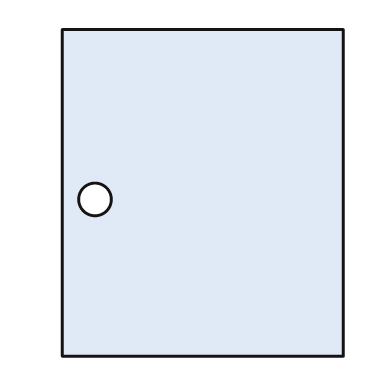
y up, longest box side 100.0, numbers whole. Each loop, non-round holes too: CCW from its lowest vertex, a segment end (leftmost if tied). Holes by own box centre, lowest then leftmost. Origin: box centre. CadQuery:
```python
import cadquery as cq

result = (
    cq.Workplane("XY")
    .moveTo(-43.0, -50.0)
    .lineTo(43.0, -50.0)
    .lineTo(43.0, 50.0)
    .lineTo(-43.0, 50.0)
    .close()
    .moveTo(-33.0, -2.0)
    .circle(5.0)
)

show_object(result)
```